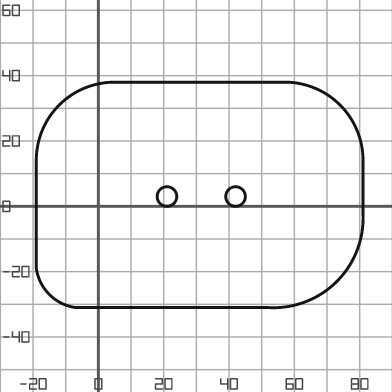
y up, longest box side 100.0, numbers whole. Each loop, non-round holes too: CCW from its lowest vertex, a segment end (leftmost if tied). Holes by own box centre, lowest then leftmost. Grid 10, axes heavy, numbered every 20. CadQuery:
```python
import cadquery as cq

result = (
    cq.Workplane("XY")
    .moveTo(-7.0, -31.0)
    .lineTo(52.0, -31.0)
    .threePointArc((73.0, -23.0), (81.0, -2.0))
    .lineTo(81.0, 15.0)
    .threePointArc((74.0, 31.0), (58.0, 38.0))
    .lineTo(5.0, 38.0)
    .threePointArc((-12.0, 31.0), (-19.0, 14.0))
    .lineTo(-19.0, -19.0)
    .threePointArc((-15.0, -27.0), (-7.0, -31.0))
    .close()
    .moveTo(21.0, 3.0)
    .circle(3.0)
    .moveTo(42.0, 3.0)
    .circle(3.0)
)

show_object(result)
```